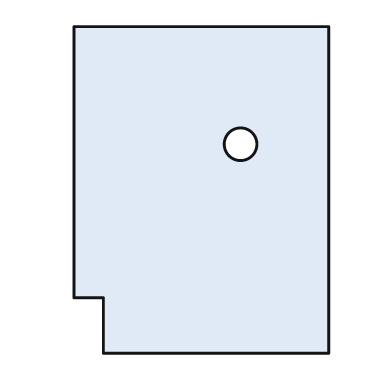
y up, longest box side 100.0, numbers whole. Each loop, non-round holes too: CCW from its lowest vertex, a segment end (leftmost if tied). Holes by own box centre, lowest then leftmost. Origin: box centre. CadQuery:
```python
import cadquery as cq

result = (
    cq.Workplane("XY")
    .moveTo(-30.0, -50.0)
    .lineTo(39.0, -50.0)
    .lineTo(39.0, 50.0)
    .lineTo(-39.0, 50.0)
    .lineTo(-39.0, -33.0)
    .lineTo(-30.0, -33.0)
    .close()
    .moveTo(12.0, 14.0)
    .circle(5.0)
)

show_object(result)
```